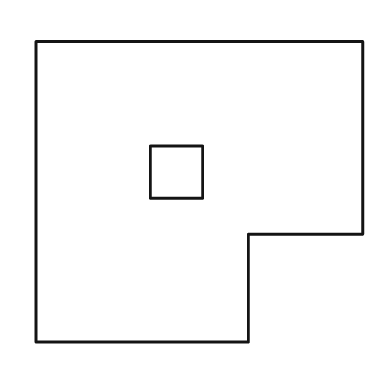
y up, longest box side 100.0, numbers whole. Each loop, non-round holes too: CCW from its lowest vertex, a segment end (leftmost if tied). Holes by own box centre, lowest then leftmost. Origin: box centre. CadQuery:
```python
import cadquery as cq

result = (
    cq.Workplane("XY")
    .moveTo(-50.0, -46.0)
    .lineTo(15.0, -46.0)
    .lineTo(15.0, -13.0)
    .lineTo(50.0, -13.0)
    .lineTo(50.0, 46.0)
    .lineTo(-50.0, 46.0)
    .close()
    .moveTo(-15.0, -2.0)
    .lineTo(1.0, -2.0)
    .lineTo(1.0, 14.0)
    .lineTo(-15.0, 14.0)
    .close()
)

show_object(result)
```